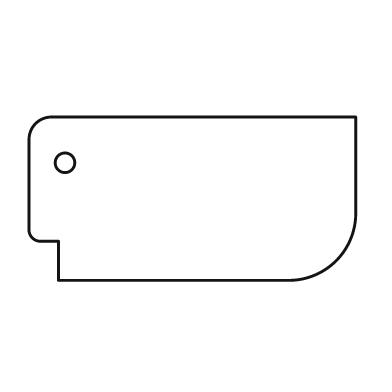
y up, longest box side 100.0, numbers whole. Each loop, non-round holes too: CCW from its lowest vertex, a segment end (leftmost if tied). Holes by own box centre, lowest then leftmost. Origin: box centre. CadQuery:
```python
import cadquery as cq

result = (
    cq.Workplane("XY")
    .moveTo(-41.0, -25.0)
    .lineTo(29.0, -25.0)
    .threePointArc((44.0, -19.0), (50.0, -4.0))
    .lineTo(50.0, 25.0)
    .lineTo(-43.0, 25.0)
    .threePointArc((-48.0, 23.0), (-50.0, 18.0))
    .lineTo(-50.0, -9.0)
    .threePointArc((-49.0, -12.0), (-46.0, -13.0))
    .lineTo(-41.0, -13.0)
    .close()
    .moveTo(-39.0, 11.0)
    .circle(3.0)
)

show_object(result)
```